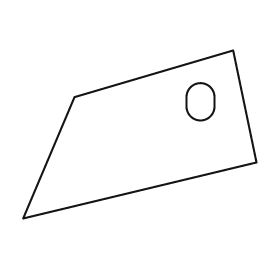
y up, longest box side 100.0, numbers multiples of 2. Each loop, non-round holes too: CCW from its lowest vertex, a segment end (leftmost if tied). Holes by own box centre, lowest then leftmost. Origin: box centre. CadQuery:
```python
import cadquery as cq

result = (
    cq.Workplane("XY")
    .moveTo(-50.0, -36.0)
    .lineTo(50.0, -12.0)
    .lineTo(40.0, 36.0)
    .lineTo(-28.0, 16.0)
    .close()
    .moveTo(20.0, 12.0)
    .threePointArc((26.0, 6.0), (32.0, 12.0))
    .lineTo(32.0, 16.0)
    .threePointArc((26.0, 22.0), (20.0, 16.0))
    .close()
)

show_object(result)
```